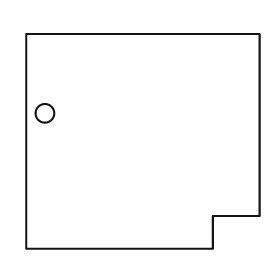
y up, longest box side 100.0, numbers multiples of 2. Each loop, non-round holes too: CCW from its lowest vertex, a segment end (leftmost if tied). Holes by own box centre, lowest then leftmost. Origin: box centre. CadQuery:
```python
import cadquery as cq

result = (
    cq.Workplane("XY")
    .moveTo(-50.0, -46.0)
    .lineTo(30.0, -46.0)
    .lineTo(30.0, -32.0)
    .lineTo(50.0, -32.0)
    .lineTo(50.0, 46.0)
    .lineTo(-50.0, 46.0)
    .close()
    .moveTo(-42.0, 12.0)
    .circle(4.0)
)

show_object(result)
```